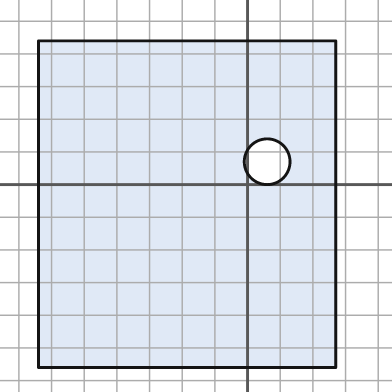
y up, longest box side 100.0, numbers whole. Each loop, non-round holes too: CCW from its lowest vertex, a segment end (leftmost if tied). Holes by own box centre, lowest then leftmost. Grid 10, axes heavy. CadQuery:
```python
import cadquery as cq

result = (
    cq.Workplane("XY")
    .moveTo(-64.0, -56.0)
    .lineTo(27.0, -56.0)
    .lineTo(27.0, 44.0)
    .lineTo(-64.0, 44.0)
    .close()
    .moveTo(6.0, 7.0)
    .circle(7.0)
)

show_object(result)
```